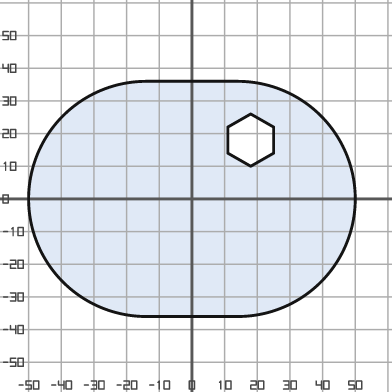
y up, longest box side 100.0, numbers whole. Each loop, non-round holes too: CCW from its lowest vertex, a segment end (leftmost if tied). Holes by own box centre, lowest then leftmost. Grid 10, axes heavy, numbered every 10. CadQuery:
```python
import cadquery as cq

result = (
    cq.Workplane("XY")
    .moveTo(-14.0, -36.0)
    .lineTo(14.0, -36.0)
    .threePointArc((50.0, 0.0), (14.0, 36.0))
    .lineTo(-14.0, 36.0)
    .threePointArc((-50.0, 0.0), (-14.0, -36.0))
    .close()
    .moveTo(18.0, 10.0)
    .lineTo(25.0, 14.0)
    .lineTo(25.0, 22.0)
    .lineTo(18.0, 26.0)
    .lineTo(11.0, 22.0)
    .lineTo(11.0, 14.0)
    .close()
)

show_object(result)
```